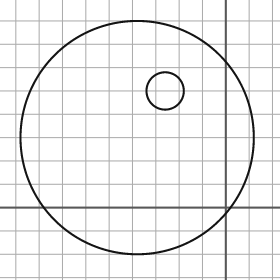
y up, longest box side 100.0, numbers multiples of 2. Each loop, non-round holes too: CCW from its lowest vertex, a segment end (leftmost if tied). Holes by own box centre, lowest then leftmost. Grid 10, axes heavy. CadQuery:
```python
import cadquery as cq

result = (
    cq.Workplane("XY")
    .moveTo(-38.0, 30.0)
    .circle(50.0)
    .moveTo(-26.0, 50.0)
    .circle(8.0)
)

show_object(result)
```